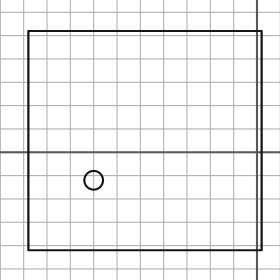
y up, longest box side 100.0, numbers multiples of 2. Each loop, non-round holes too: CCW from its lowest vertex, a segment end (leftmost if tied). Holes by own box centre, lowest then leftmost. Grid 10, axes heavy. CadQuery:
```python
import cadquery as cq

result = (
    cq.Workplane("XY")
    .moveTo(-98.0, -42.0)
    .lineTo(2.0, -42.0)
    .lineTo(2.0, 52.0)
    .lineTo(-98.0, 52.0)
    .close()
    .moveTo(-70.0, -12.0)
    .circle(4.0)
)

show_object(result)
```